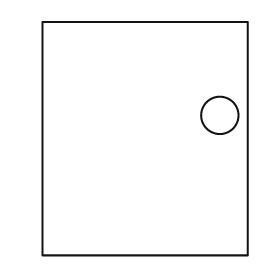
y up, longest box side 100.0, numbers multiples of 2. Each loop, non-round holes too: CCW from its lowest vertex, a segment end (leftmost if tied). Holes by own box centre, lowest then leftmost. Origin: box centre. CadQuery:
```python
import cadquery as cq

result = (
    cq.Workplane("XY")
    .moveTo(-44.0, -50.0)
    .lineTo(44.0, -50.0)
    .lineTo(44.0, 50.0)
    .lineTo(-44.0, 50.0)
    .close()
    .moveTo(32.0, 10.0)
    .circle(8.0)
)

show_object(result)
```